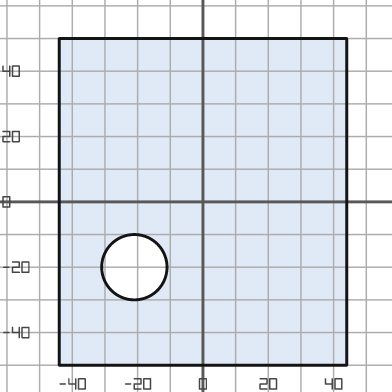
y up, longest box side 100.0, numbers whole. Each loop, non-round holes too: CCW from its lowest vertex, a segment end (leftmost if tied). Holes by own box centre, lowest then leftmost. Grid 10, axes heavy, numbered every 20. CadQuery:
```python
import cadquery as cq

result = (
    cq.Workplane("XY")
    .moveTo(-44.0, -50.0)
    .lineTo(44.0, -50.0)
    .lineTo(44.0, 50.0)
    .lineTo(-44.0, 50.0)
    .close()
    .moveTo(-21.0, -20.0)
    .circle(10.0)
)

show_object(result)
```